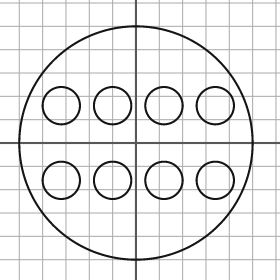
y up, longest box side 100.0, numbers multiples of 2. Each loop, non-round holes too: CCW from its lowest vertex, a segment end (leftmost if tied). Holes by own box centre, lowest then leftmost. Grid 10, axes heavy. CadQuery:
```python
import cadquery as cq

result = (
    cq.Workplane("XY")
    .moveTo(0.0, 0.0)
    .circle(50.0)
    .moveTo(-32.0, -16.0)
    .circle(8.0)
    .moveTo(-10.0, -16.0)
    .circle(8.0)
    .moveTo(12.0, -16.0)
    .circle(8.0)
    .moveTo(34.0, -16.0)
    .circle(8.0)
    .moveTo(-32.0, 16.0)
    .circle(8.0)
    .moveTo(-10.0, 16.0)
    .circle(8.0)
    .moveTo(12.0, 16.0)
    .circle(8.0)
    .moveTo(34.0, 16.0)
    .circle(8.0)
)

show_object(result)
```